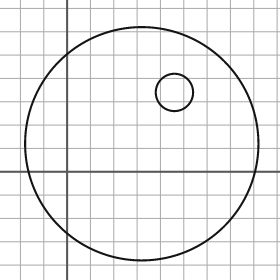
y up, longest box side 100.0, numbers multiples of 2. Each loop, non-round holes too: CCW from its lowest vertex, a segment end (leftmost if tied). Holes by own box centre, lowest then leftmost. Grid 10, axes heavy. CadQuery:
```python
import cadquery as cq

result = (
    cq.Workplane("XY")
    .moveTo(32.0, 12.0)
    .circle(50.0)
    .moveTo(46.0, 34.0)
    .circle(8.0)
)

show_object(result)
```